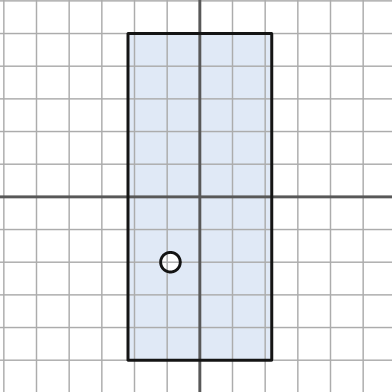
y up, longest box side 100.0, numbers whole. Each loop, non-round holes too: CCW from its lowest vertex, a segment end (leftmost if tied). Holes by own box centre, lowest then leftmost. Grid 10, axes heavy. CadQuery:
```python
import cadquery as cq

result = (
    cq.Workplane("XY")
    .moveTo(-22.0, -50.0)
    .lineTo(22.0, -50.0)
    .lineTo(22.0, 50.0)
    .lineTo(-22.0, 50.0)
    .close()
    .moveTo(-9.0, -20.0)
    .circle(3.0)
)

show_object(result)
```